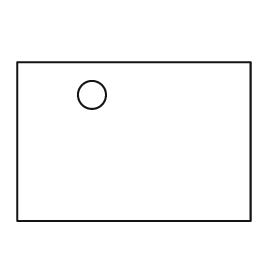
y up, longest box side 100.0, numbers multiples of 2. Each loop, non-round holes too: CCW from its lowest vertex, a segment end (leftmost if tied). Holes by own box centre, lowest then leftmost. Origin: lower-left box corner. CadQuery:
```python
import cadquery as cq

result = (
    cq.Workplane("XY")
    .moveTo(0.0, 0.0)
    .lineTo(100.0, 0.0)
    .lineTo(100.0, 68.0)
    .lineTo(0.0, 68.0)
    .close()
    .moveTo(32.0, 54.0)
    .circle(6.0)
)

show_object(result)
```